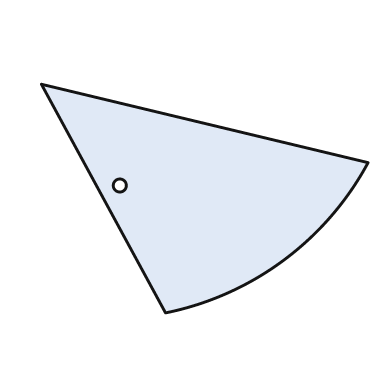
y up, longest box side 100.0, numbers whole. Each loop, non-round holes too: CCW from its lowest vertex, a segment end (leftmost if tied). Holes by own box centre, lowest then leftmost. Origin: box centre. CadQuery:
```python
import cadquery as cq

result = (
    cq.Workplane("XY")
    .moveTo(-12.0, -35.0)
    .threePointArc((24.0, -19.0), (50.0, 11.0))
    .lineTo(-50.0, 35.0)
    .close()
    .moveTo(-26.0, 4.0)
    .circle(2.0)
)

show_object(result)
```